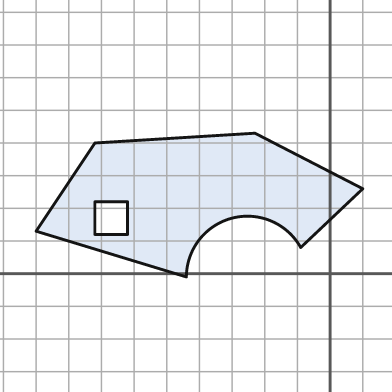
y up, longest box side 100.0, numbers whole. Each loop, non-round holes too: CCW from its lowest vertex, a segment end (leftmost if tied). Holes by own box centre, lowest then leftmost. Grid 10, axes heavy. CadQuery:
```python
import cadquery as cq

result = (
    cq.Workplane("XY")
    .moveTo(-44.0, -1.0)
    .threePointArc((-30.0, 17.0), (-9.0, 8.0))
    .lineTo(10.0, 26.0)
    .lineTo(-23.0, 43.0)
    .lineTo(-72.0, 40.0)
    .lineTo(-90.0, 13.0)
    .close()
    .moveTo(-72.0, 12.0)
    .lineTo(-62.0, 12.0)
    .lineTo(-62.0, 22.0)
    .lineTo(-72.0, 22.0)
    .close()
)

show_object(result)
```